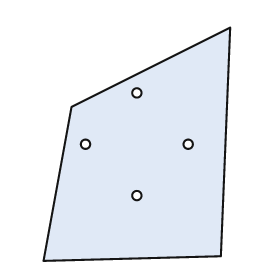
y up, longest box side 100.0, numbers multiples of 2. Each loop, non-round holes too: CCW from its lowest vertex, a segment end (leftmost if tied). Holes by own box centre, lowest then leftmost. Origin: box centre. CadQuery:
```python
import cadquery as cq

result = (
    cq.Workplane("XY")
    .moveTo(-40.0, -50.0)
    .lineTo(36.0, -48.0)
    .lineTo(40.0, 50.0)
    .lineTo(-28.0, 16.0)
    .close()
    .moveTo(0.0, -22.0)
    .circle(2.0)
    .moveTo(-22.0, 0.0)
    .circle(2.0)
    .moveTo(22.0, 0.0)
    .circle(2.0)
    .moveTo(0.0, 22.0)
    .circle(2.0)
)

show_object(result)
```